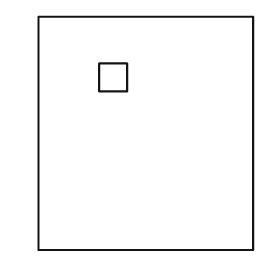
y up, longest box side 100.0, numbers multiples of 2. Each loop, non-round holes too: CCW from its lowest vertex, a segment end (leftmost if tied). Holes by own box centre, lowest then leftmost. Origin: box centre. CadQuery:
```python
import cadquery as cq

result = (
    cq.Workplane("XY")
    .moveTo(-46.0, -50.0)
    .lineTo(46.0, -50.0)
    .lineTo(46.0, 50.0)
    .lineTo(-46.0, 50.0)
    .close()
    .moveTo(-20.0, 18.0)
    .lineTo(-8.0, 18.0)
    .lineTo(-8.0, 30.0)
    .lineTo(-20.0, 30.0)
    .close()
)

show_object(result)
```